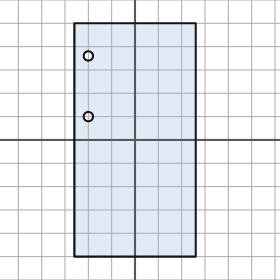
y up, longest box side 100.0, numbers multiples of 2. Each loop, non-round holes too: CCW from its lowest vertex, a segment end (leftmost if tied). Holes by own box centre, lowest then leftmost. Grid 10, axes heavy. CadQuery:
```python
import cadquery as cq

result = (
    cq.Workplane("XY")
    .moveTo(-26.0, -50.0)
    .lineTo(26.0, -50.0)
    .lineTo(26.0, 50.0)
    .lineTo(-26.0, 50.0)
    .close()
    .moveTo(-20.0, 10.0)
    .circle(2.0)
    .moveTo(-20.0, 36.0)
    .circle(2.0)
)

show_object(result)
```